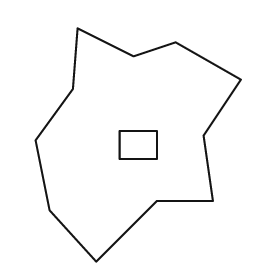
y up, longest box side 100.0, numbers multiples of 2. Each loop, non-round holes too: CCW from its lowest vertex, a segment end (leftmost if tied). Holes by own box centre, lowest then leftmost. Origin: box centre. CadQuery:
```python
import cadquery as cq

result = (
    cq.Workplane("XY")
    .moveTo(-18.0, -50.0)
    .lineTo(8.0, -24.0)
    .lineTo(32.0, -24.0)
    .lineTo(28.0, 4.0)
    .lineTo(44.0, 28.0)
    .lineTo(16.0, 44.0)
    .lineTo(-2.0, 38.0)
    .lineTo(-26.0, 50.0)
    .lineTo(-28.0, 24.0)
    .lineTo(-44.0, 2.0)
    .lineTo(-38.0, -28.0)
    .close()
    .moveTo(-8.0, -6.0)
    .lineTo(8.0, -6.0)
    .lineTo(8.0, 6.0)
    .lineTo(-8.0, 6.0)
    .close()
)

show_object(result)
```